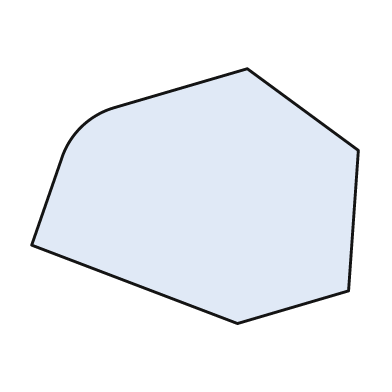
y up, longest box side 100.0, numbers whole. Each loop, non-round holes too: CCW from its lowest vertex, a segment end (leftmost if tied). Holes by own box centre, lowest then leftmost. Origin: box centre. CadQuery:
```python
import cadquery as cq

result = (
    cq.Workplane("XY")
    .moveTo(13.0, -39.0)
    .lineTo(47.0, -29.0)
    .lineTo(50.0, 14.0)
    .lineTo(16.0, 39.0)
    .lineTo(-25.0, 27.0)
    .threePointArc((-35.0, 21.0), (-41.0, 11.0))
    .lineTo(-50.0, -15.0)
    .close()
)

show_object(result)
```